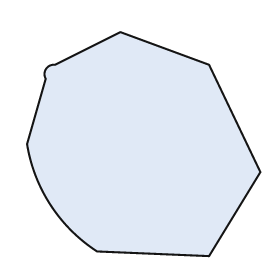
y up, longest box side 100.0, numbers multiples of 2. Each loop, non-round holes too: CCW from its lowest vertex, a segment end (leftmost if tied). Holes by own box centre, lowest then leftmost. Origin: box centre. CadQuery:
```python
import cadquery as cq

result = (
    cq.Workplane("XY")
    .moveTo(28.0, -48.0)
    .lineTo(50.0, -12.0)
    .lineTo(28.0, 34.0)
    .lineTo(-10.0, 48.0)
    .lineTo(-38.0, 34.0)
    .threePointArc((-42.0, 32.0), (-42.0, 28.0))
    .lineTo(-50.0, 0.0)
    .threePointArc((-40.0, -26.0), (-20.0, -46.0))
    .close()
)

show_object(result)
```